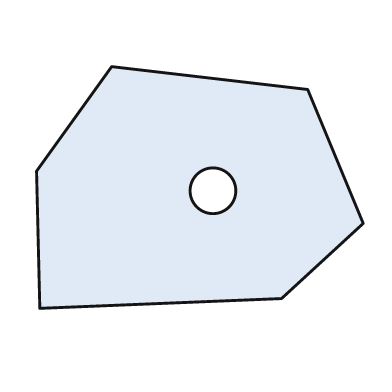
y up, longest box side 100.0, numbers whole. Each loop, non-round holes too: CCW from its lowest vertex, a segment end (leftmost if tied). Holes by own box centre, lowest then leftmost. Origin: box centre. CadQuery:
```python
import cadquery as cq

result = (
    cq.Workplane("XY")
    .moveTo(-49.0, -37.0)
    .lineTo(25.0, -34.0)
    .lineTo(50.0, -11.0)
    .lineTo(33.0, 30.0)
    .lineTo(-27.0, 37.0)
    .lineTo(-50.0, 5.0)
    .close()
    .moveTo(4.0, -1.0)
    .circle(7.0)
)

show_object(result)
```